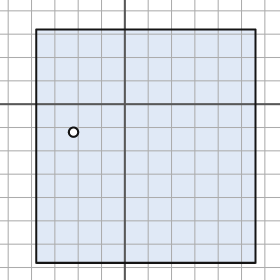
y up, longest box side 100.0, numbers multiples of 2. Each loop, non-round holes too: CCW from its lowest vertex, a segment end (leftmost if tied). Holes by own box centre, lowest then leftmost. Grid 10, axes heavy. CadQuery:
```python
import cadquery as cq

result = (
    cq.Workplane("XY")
    .moveTo(-38.0, -68.0)
    .lineTo(56.0, -68.0)
    .lineTo(56.0, 32.0)
    .lineTo(-38.0, 32.0)
    .close()
    .moveTo(-22.0, -12.0)
    .circle(2.0)
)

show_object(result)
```